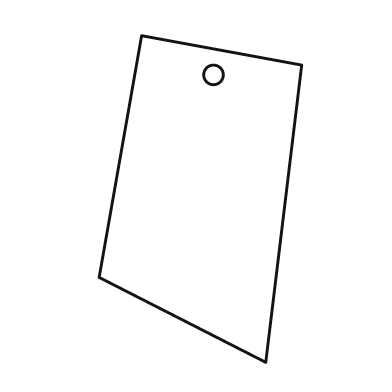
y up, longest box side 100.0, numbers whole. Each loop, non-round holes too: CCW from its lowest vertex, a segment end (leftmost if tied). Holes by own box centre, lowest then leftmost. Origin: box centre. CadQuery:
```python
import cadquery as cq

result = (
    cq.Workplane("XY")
    .moveTo(20.0, -50.0)
    .lineTo(31.0, 41.0)
    .lineTo(-18.0, 50.0)
    .lineTo(-31.0, -24.0)
    .close()
    .moveTo(4.0, 38.0)
    .circle(3.0)
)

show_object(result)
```